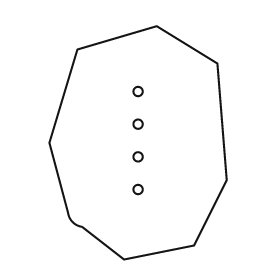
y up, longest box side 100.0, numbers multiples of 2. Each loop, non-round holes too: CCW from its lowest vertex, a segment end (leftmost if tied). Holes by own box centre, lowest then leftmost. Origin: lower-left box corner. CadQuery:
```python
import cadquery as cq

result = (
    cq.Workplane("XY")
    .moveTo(32.0, 0.0)
    .lineTo(62.0, 6.0)
    .lineTo(76.0, 34.0)
    .lineTo(72.0, 84.0)
    .lineTo(46.0, 100.0)
    .lineTo(12.0, 90.0)
    .lineTo(0.0, 50.0)
    .lineTo(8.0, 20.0)
    .threePointArc((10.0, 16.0), (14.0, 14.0))
    .close()
    .moveTo(38.0, 30.0)
    .circle(2.0)
    .moveTo(38.0, 44.0)
    .circle(2.0)
    .moveTo(38.0, 58.0)
    .circle(2.0)
    .moveTo(38.0, 72.0)
    .circle(2.0)
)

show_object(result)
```